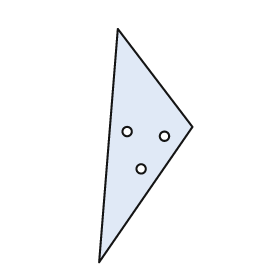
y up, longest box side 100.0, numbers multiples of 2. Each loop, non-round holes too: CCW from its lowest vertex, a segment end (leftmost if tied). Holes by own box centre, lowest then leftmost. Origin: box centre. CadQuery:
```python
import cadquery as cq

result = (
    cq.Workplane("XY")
    .moveTo(-20.0, -50.0)
    .lineTo(20.0, 8.0)
    .lineTo(-12.0, 50.0)
    .close()
    .moveTo(-2.0, -10.0)
    .circle(2.0)
    .moveTo(8.0, 4.0)
    .circle(2.0)
    .moveTo(-8.0, 6.0)
    .circle(2.0)
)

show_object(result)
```